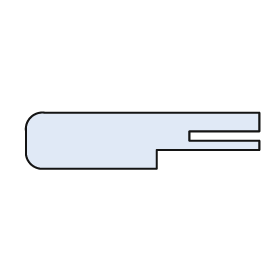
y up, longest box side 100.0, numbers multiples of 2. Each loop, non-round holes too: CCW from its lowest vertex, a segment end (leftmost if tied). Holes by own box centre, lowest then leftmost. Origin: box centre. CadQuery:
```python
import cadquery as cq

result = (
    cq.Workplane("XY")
    .moveTo(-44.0, -12.0)
    .lineTo(6.0, -12.0)
    .lineTo(6.0, -4.0)
    .lineTo(50.0, -4.0)
    .lineTo(50.0, 0.0)
    .lineTo(20.0, 0.0)
    .lineTo(20.0, 4.0)
    .lineTo(50.0, 4.0)
    .lineTo(50.0, 12.0)
    .lineTo(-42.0, 12.0)
    .threePointArc((-48.0, 10.0), (-50.0, 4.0))
    .lineTo(-50.0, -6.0)
    .threePointArc((-48.0, -10.0), (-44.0, -12.0))
    .close()
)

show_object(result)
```